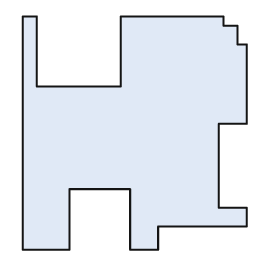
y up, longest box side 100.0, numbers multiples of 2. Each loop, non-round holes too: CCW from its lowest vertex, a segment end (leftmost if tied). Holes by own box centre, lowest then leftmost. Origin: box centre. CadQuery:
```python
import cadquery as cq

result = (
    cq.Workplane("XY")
    .moveTo(-48.0, -50.0)
    .lineTo(-28.0, -50.0)
    .lineTo(-28.0, -24.0)
    .lineTo(-2.0, -24.0)
    .lineTo(-2.0, -50.0)
    .lineTo(10.0, -50.0)
    .lineTo(10.0, -40.0)
    .lineTo(48.0, -40.0)
    .lineTo(48.0, -32.0)
    .lineTo(36.0, -32.0)
    .lineTo(36.0, 4.0)
    .lineTo(48.0, 4.0)
    .lineTo(48.0, 38.0)
    .lineTo(44.0, 38.0)
    .lineTo(44.0, 46.0)
    .lineTo(38.0, 46.0)
    .lineTo(38.0, 50.0)
    .lineTo(-6.0, 50.0)
    .lineTo(-6.0, 20.0)
    .lineTo(-42.0, 20.0)
    .lineTo(-42.0, 50.0)
    .lineTo(-48.0, 50.0)
    .close()
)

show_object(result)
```